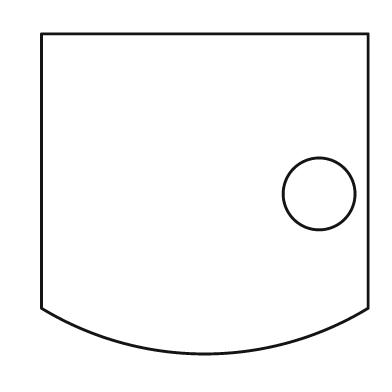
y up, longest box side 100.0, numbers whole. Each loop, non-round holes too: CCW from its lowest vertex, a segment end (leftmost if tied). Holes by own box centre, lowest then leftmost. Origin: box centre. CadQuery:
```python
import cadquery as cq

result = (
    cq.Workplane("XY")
    .moveTo(-50.0, -35.0)
    .threePointArc((0.0, -49.0), (50.0, -35.0))
    .lineTo(50.0, 49.0)
    .lineTo(-50.0, 49.0)
    .close()
    .moveTo(35.0, 0.0)
    .circle(11.0)
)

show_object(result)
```